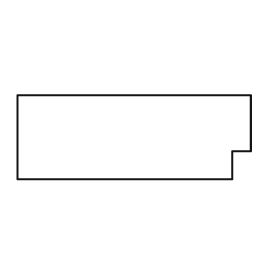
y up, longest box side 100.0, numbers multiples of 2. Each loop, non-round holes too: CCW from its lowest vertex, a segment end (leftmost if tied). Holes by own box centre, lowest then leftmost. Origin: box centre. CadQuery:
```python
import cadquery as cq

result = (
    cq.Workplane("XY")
    .moveTo(-50.0, -18.0)
    .lineTo(42.0, -18.0)
    .lineTo(42.0, -6.0)
    .lineTo(50.0, -6.0)
    .lineTo(50.0, 18.0)
    .lineTo(-50.0, 18.0)
    .close()
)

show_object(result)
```